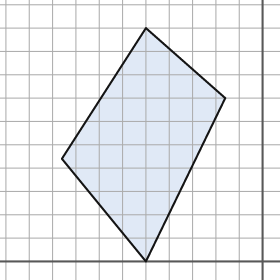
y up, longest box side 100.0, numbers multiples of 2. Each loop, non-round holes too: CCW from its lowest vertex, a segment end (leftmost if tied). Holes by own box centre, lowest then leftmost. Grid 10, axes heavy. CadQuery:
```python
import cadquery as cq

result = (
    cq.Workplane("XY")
    .moveTo(-50.0, 0.0)
    .lineTo(-16.0, 70.0)
    .lineTo(-50.0, 100.0)
    .lineTo(-86.0, 44.0)
    .close()
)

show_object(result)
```